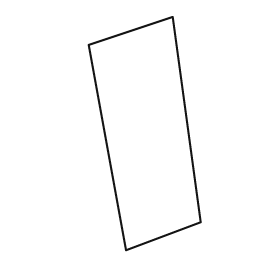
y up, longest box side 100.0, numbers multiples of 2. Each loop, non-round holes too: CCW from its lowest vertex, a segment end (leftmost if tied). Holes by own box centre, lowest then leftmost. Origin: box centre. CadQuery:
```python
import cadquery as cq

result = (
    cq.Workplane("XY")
    .moveTo(-8.0, -50.0)
    .lineTo(24.0, -38.0)
    .lineTo(12.0, 50.0)
    .lineTo(-24.0, 38.0)
    .close()
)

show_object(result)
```